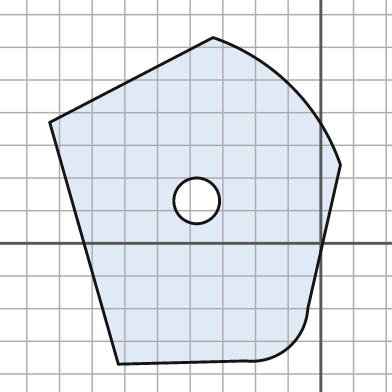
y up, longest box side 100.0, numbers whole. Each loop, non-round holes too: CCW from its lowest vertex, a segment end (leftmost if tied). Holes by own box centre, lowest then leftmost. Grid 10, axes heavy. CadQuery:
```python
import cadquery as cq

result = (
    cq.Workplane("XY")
    .moveTo(-62.0, -37.0)
    .lineTo(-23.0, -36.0)
    .threePointArc((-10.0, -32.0), (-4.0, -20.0))
    .lineTo(6.0, 24.0)
    .threePointArc((-9.0, 48.0), (-33.0, 63.0))
    .lineTo(-83.0, 37.0)
    .close()
    .moveTo(-38.0, 13.0)
    .circle(7.0)
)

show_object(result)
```